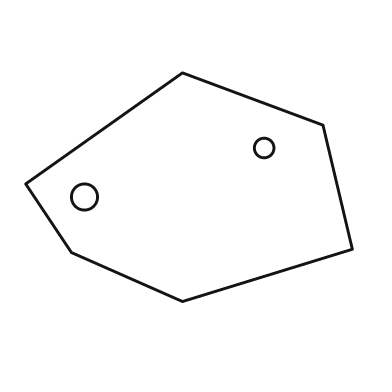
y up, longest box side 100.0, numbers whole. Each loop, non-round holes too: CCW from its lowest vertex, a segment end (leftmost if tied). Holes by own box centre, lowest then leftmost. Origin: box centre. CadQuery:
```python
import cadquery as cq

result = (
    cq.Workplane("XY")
    .moveTo(-2.0, -35.0)
    .lineTo(50.0, -19.0)
    .lineTo(41.0, 19.0)
    .lineTo(-2.0, 35.0)
    .lineTo(-50.0, 1.0)
    .lineTo(-36.0, -20.0)
    .close()
    .moveTo(-32.0, -3.0)
    .circle(4.0)
    .moveTo(23.0, 12.0)
    .circle(3.0)
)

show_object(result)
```